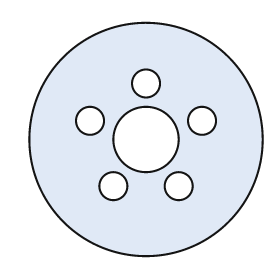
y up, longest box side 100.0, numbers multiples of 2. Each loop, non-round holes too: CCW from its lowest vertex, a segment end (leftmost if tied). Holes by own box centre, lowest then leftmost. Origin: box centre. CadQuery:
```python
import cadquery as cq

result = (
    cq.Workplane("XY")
    .moveTo(0.0, 0.0)
    .circle(50.0)
    .moveTo(-14.0, -20.0)
    .circle(6.0)
    .moveTo(14.0, -20.0)
    .circle(6.0)
    .moveTo(0.0, 0.0)
    .circle(14.0)
    .moveTo(-24.0, 8.0)
    .circle(6.0)
    .moveTo(24.0, 8.0)
    .circle(6.0)
    .moveTo(0.0, 24.0)
    .circle(6.0)
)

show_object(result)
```